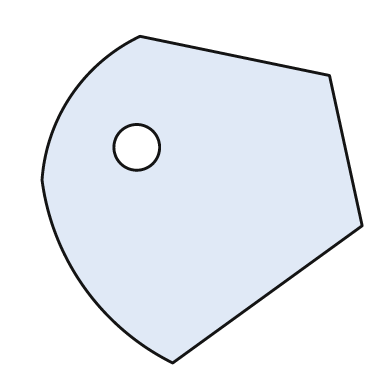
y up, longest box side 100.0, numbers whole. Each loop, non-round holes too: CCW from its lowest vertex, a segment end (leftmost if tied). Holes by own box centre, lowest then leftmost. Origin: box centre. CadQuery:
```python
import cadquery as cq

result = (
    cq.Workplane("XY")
    .moveTo(-9.0, -50.0)
    .lineTo(49.0, -8.0)
    .lineTo(39.0, 38.0)
    .lineTo(-19.0, 50.0)
    .threePointArc((-40.0, 32.0), (-49.0, 6.0))
    .threePointArc((-36.0, -27.0), (-9.0, -50.0))
    .close()
    .moveTo(-20.0, 16.0)
    .circle(7.0)
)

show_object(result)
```